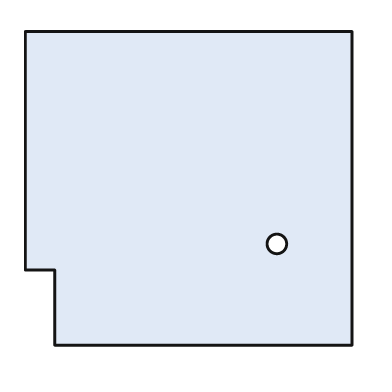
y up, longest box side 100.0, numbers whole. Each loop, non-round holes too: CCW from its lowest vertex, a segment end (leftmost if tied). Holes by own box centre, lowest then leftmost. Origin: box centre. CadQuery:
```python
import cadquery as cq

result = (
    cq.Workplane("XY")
    .moveTo(-41.0, -48.0)
    .lineTo(50.0, -48.0)
    .lineTo(50.0, 48.0)
    .lineTo(-50.0, 48.0)
    .lineTo(-50.0, -25.0)
    .lineTo(-41.0, -25.0)
    .close()
    .moveTo(27.0, -17.0)
    .circle(3.0)
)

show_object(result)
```